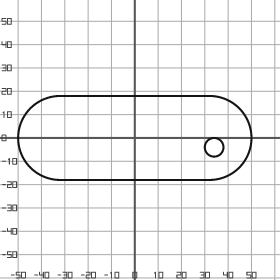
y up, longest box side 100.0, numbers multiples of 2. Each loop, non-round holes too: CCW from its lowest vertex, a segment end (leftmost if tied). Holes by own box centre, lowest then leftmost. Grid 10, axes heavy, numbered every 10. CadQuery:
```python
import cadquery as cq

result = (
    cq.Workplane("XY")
    .moveTo(-32.0, -18.0)
    .lineTo(32.0, -18.0)
    .threePointArc((50.0, 0.0), (32.0, 18.0))
    .lineTo(-32.0, 18.0)
    .threePointArc((-50.0, 0.0), (-32.0, -18.0))
    .close()
    .moveTo(34.0, -4.0)
    .circle(4.0)
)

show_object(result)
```